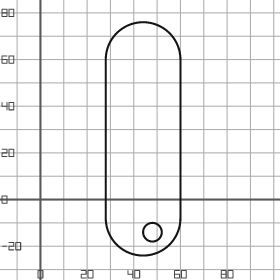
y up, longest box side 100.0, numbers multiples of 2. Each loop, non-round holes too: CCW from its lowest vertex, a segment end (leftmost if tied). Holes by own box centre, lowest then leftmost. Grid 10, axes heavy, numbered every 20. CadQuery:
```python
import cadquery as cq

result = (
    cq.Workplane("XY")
    .moveTo(28.0, -8.0)
    .threePointArc((44.0, -24.0), (60.0, -8.0))
    .lineTo(60.0, 60.0)
    .threePointArc((44.0, 76.0), (28.0, 60.0))
    .close()
    .moveTo(48.0, -14.0)
    .circle(4.0)
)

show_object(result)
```